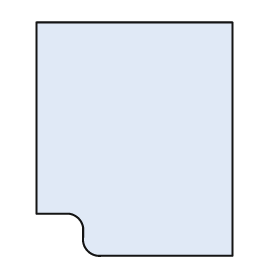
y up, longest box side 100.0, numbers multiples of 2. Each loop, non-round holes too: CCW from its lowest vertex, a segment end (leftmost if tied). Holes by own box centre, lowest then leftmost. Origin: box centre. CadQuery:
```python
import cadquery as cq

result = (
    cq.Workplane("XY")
    .moveTo(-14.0, -50.0)
    .lineTo(42.0, -50.0)
    .lineTo(42.0, 50.0)
    .lineTo(-42.0, 50.0)
    .lineTo(-42.0, -32.0)
    .lineTo(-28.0, -32.0)
    .threePointArc((-24.0, -34.0), (-22.0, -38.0))
    .lineTo(-22.0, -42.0)
    .threePointArc((-20.0, -48.0), (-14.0, -50.0))
    .close()
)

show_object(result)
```